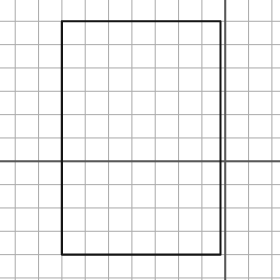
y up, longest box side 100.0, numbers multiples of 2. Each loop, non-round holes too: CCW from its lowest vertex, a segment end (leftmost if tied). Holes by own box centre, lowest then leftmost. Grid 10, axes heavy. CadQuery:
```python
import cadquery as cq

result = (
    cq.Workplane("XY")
    .moveTo(-70.0, -40.0)
    .lineTo(-2.0, -40.0)
    .lineTo(-2.0, 60.0)
    .lineTo(-70.0, 60.0)
    .close()
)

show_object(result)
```